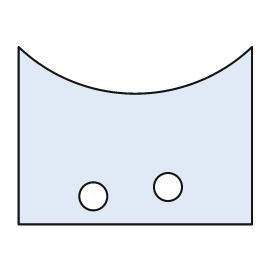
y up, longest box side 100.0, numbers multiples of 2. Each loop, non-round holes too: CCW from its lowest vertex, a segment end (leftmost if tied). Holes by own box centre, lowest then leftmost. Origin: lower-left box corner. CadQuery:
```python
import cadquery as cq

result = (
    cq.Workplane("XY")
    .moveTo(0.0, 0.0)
    .lineTo(100.0, 0.0)
    .lineTo(100.0, 76.0)
    .threePointArc((50.0, 56.0), (0.0, 76.0))
    .close()
    .moveTo(32.0, 12.0)
    .circle(6.0)
    .moveTo(64.0, 16.0)
    .circle(6.0)
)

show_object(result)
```